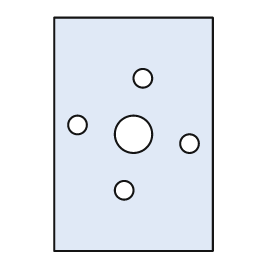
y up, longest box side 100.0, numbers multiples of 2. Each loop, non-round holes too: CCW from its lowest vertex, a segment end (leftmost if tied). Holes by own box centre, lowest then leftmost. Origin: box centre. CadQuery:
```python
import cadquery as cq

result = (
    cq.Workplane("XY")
    .moveTo(-34.0, -50.0)
    .lineTo(34.0, -50.0)
    .lineTo(34.0, 50.0)
    .lineTo(-34.0, 50.0)
    .close()
    .moveTo(-4.0, -24.0)
    .circle(4.0)
    .moveTo(24.0, -4.0)
    .circle(4.0)
    .moveTo(0.0, 0.0)
    .circle(8.0)
    .moveTo(-24.0, 4.0)
    .circle(4.0)
    .moveTo(4.0, 24.0)
    .circle(4.0)
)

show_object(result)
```